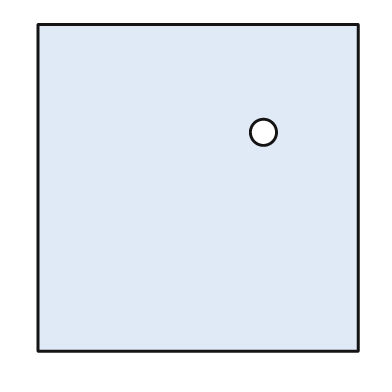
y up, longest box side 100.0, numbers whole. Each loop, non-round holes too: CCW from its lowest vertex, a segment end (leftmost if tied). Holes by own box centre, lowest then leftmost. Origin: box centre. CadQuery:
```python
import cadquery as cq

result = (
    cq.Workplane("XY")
    .moveTo(-49.0, -50.0)
    .lineTo(49.0, -50.0)
    .lineTo(49.0, 50.0)
    .lineTo(-49.0, 50.0)
    .close()
    .moveTo(20.0, 17.0)
    .circle(4.0)
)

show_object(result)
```